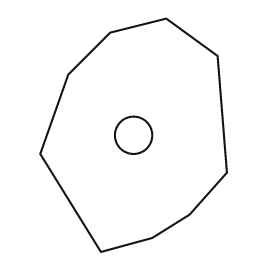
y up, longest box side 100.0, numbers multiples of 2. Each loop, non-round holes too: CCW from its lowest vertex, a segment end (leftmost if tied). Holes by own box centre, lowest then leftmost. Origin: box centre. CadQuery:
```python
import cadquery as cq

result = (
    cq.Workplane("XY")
    .moveTo(-14.0, -50.0)
    .lineTo(8.0, -44.0)
    .lineTo(24.0, -34.0)
    .lineTo(40.0, -16.0)
    .lineTo(36.0, 34.0)
    .lineTo(14.0, 50.0)
    .lineTo(-10.0, 44.0)
    .lineTo(-28.0, 26.0)
    .lineTo(-40.0, -8.0)
    .close()
    .moveTo(0.0, 0.0)
    .circle(8.0)
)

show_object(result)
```